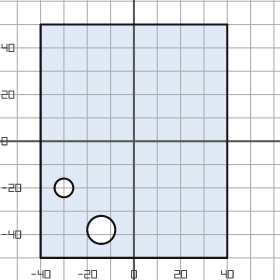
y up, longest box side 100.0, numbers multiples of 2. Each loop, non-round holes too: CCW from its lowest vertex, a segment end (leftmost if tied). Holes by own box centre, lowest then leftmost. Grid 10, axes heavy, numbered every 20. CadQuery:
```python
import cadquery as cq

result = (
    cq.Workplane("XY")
    .moveTo(-40.0, -50.0)
    .lineTo(40.0, -50.0)
    .lineTo(40.0, 50.0)
    .lineTo(-40.0, 50.0)
    .close()
    .moveTo(-14.0, -38.0)
    .circle(6.0)
    .moveTo(-30.0, -20.0)
    .circle(4.0)
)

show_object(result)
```